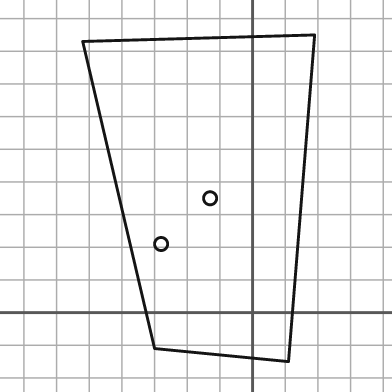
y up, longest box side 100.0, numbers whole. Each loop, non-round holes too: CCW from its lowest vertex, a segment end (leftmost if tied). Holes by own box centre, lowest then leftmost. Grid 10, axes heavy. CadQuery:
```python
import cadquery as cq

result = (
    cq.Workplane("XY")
    .moveTo(11.0, -15.0)
    .lineTo(19.0, 85.0)
    .lineTo(-52.0, 83.0)
    .lineTo(-30.0, -11.0)
    .close()
    .moveTo(-28.0, 21.0)
    .circle(2.0)
    .moveTo(-13.0, 35.0)
    .circle(2.0)
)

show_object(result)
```